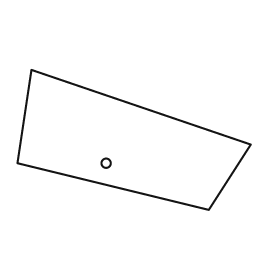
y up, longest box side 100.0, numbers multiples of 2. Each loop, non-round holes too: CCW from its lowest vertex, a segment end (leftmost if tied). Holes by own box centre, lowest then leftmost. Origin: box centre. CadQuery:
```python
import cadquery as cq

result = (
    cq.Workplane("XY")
    .moveTo(32.0, -30.0)
    .lineTo(50.0, -2.0)
    .lineTo(-44.0, 30.0)
    .lineTo(-50.0, -10.0)
    .close()
    .moveTo(-12.0, -10.0)
    .circle(2.0)
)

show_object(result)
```